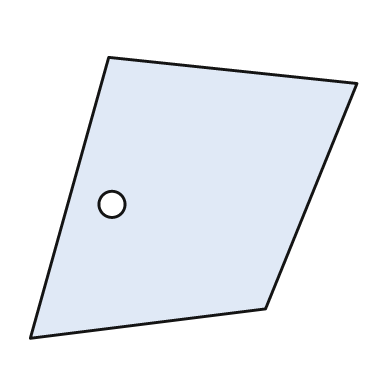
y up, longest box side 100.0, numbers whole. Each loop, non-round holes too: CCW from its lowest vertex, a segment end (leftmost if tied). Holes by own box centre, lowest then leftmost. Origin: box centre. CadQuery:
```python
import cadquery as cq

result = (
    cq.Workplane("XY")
    .moveTo(-50.0, -43.0)
    .lineTo(22.0, -34.0)
    .lineTo(50.0, 35.0)
    .lineTo(-26.0, 43.0)
    .close()
    .moveTo(-25.0, -2.0)
    .circle(4.0)
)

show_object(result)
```